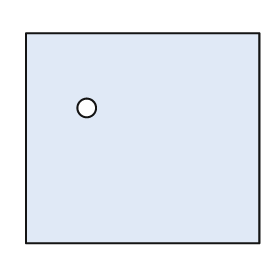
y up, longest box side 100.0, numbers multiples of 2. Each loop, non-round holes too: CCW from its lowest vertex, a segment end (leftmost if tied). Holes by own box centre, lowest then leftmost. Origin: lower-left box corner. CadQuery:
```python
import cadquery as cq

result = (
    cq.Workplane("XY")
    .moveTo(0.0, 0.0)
    .lineTo(100.0, 0.0)
    .lineTo(100.0, 90.0)
    .lineTo(0.0, 90.0)
    .close()
    .moveTo(26.0, 58.0)
    .circle(4.0)
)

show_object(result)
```